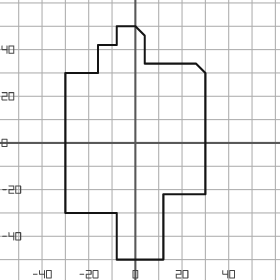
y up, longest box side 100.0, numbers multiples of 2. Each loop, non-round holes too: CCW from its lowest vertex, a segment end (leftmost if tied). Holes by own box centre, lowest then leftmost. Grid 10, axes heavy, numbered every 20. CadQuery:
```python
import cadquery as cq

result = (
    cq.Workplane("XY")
    .moveTo(-8.0, -50.0)
    .lineTo(12.0, -50.0)
    .lineTo(12.0, -22.0)
    .lineTo(30.0, -22.0)
    .lineTo(30.0, 30.0)
    .lineTo(26.0, 34.0)
    .lineTo(4.0, 34.0)
    .lineTo(4.0, 46.0)
    .lineTo(0.0, 50.0)
    .lineTo(-8.0, 50.0)
    .lineTo(-8.0, 42.0)
    .lineTo(-16.0, 42.0)
    .lineTo(-16.0, 30.0)
    .lineTo(-30.0, 30.0)
    .lineTo(-30.0, -30.0)
    .lineTo(-8.0, -30.0)
    .close()
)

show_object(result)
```